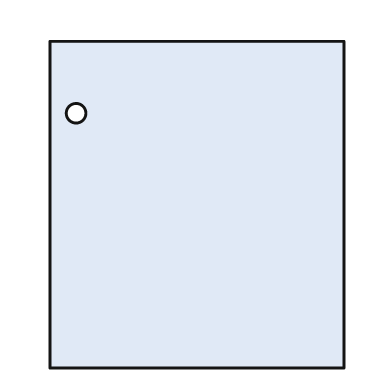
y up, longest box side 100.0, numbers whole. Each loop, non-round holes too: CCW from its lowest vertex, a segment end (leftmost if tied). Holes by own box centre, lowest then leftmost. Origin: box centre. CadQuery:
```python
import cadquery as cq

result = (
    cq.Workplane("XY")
    .moveTo(-45.0, -50.0)
    .lineTo(45.0, -50.0)
    .lineTo(45.0, 50.0)
    .lineTo(-45.0, 50.0)
    .close()
    .moveTo(-37.0, 28.0)
    .circle(3.0)
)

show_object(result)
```